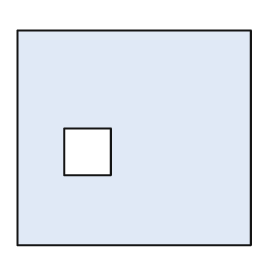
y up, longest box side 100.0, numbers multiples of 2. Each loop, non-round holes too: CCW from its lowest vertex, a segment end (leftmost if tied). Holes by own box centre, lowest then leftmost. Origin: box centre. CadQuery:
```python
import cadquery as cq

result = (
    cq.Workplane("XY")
    .moveTo(-50.0, -46.0)
    .lineTo(50.0, -46.0)
    .lineTo(50.0, 46.0)
    .lineTo(-50.0, 46.0)
    .close()
    .moveTo(-30.0, -16.0)
    .lineTo(-10.0, -16.0)
    .lineTo(-10.0, 4.0)
    .lineTo(-30.0, 4.0)
    .close()
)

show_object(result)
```